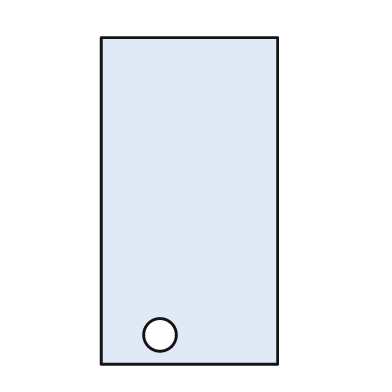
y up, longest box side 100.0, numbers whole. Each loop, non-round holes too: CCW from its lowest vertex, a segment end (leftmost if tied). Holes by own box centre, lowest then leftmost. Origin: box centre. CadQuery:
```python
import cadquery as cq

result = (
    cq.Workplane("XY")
    .moveTo(-27.0, -50.0)
    .lineTo(27.0, -50.0)
    .lineTo(27.0, 50.0)
    .lineTo(-27.0, 50.0)
    .close()
    .moveTo(-9.0, -41.0)
    .circle(5.0)
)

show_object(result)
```